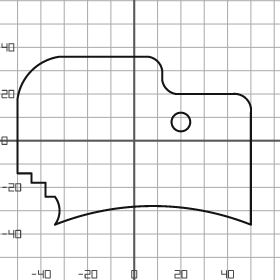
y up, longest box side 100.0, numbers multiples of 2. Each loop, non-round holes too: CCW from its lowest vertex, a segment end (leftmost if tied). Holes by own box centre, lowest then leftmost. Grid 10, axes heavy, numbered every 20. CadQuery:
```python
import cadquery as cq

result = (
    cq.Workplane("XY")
    .moveTo(-34.0, -36.0)
    .threePointArc((8.0, -28.0), (50.0, -36.0))
    .lineTo(50.0, 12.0)
    .threePointArc((48.0, 18.0), (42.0, 20.0))
    .lineTo(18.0, 20.0)
    .threePointArc((14.0, 22.0), (12.0, 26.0))
    .lineTo(12.0, 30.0)
    .threePointArc((10.0, 34.0), (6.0, 36.0))
    .lineTo(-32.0, 36.0)
    .threePointArc((-44.0, 30.0), (-50.0, 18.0))
    .lineTo(-50.0, -14.0)
    .lineTo(-44.0, -14.0)
    .lineTo(-44.0, -18.0)
    .lineTo(-38.0, -18.0)
    .lineTo(-38.0, -24.0)
    .lineTo(-34.0, -24.0)
    .threePointArc((-32.0, -30.0), (-34.0, -36.0))
    .close()
    .moveTo(20.0, 8.0)
    .circle(4.0)
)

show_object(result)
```